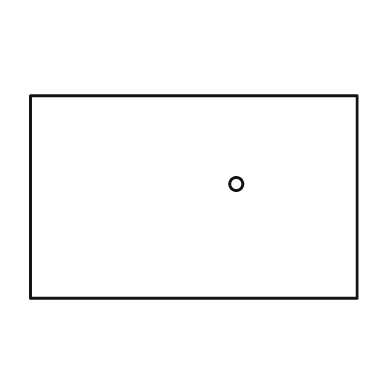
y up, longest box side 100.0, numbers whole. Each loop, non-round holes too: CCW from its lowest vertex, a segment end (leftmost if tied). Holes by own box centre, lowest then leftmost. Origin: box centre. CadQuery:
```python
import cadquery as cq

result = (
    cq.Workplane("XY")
    .moveTo(-50.0, -31.0)
    .lineTo(50.0, -31.0)
    .lineTo(50.0, 31.0)
    .lineTo(-50.0, 31.0)
    .close()
    .moveTo(13.0, 4.0)
    .circle(2.0)
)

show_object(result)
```